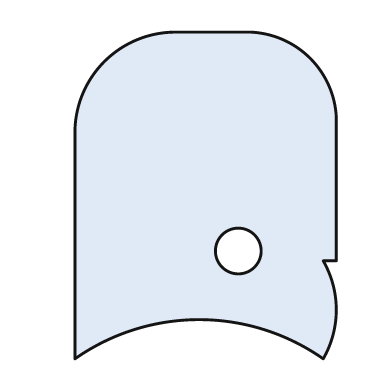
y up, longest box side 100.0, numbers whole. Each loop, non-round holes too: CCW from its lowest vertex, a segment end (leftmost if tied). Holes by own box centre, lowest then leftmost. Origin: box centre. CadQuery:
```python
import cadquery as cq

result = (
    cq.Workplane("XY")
    .moveTo(-40.0, -50.0)
    .threePointArc((-2.0, -38.0), (36.0, -50.0))
    .threePointArc((40.0, -35.0), (36.0, -20.0))
    .lineTo(40.0, -20.0)
    .lineTo(40.0, 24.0)
    .threePointArc((32.0, 42.0), (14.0, 50.0))
    .lineTo(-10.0, 50.0)
    .threePointArc((-31.0, 41.0), (-40.0, 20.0))
    .close()
    .moveTo(10.0, -17.0)
    .circle(7.0)
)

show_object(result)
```